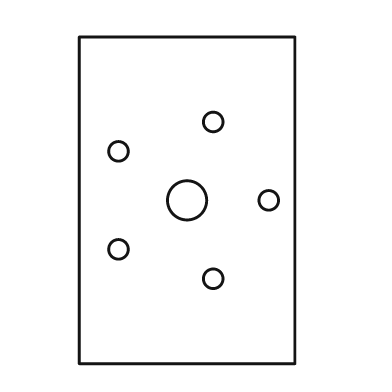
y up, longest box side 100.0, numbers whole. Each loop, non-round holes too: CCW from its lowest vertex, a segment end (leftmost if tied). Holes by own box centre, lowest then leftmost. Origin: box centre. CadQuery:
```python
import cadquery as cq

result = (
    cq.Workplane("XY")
    .moveTo(-33.0, -50.0)
    .lineTo(33.0, -50.0)
    .lineTo(33.0, 50.0)
    .lineTo(-33.0, 50.0)
    .close()
    .moveTo(8.0, -24.0)
    .circle(3.0)
    .moveTo(-21.0, -15.0)
    .circle(3.0)
    .moveTo(0.0, 0.0)
    .circle(6.0)
    .moveTo(25.0, 0.0)
    .circle(3.0)
    .moveTo(-21.0, 15.0)
    .circle(3.0)
    .moveTo(8.0, 24.0)
    .circle(3.0)
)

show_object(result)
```